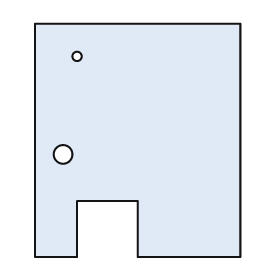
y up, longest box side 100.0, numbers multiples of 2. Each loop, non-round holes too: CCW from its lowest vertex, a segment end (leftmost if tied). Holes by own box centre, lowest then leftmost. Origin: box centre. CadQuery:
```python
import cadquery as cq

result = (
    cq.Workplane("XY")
    .moveTo(-44.0, -50.0)
    .lineTo(-26.0, -50.0)
    .lineTo(-26.0, -26.0)
    .lineTo(0.0, -26.0)
    .lineTo(0.0, -50.0)
    .lineTo(44.0, -50.0)
    .lineTo(44.0, 50.0)
    .lineTo(-44.0, 50.0)
    .close()
    .moveTo(-32.0, -6.0)
    .circle(4.0)
    .moveTo(-26.0, 36.0)
    .circle(2.0)
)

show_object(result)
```